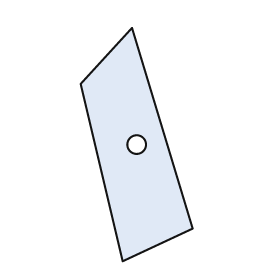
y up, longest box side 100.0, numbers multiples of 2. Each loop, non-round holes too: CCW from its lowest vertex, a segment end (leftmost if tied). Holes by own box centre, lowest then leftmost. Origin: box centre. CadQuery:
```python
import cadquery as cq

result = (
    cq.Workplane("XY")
    .moveTo(-6.0, -50.0)
    .lineTo(24.0, -36.0)
    .lineTo(-2.0, 50.0)
    .lineTo(-24.0, 26.0)
    .close()
    .moveTo(0.0, 0.0)
    .circle(4.0)
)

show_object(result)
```